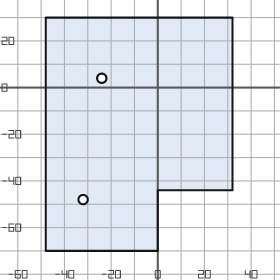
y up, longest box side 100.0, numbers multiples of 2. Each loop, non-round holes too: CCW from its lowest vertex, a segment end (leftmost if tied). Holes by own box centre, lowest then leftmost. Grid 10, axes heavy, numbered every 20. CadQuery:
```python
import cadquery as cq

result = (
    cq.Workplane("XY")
    .moveTo(-48.0, -70.0)
    .lineTo(0.0, -70.0)
    .lineTo(0.0, -44.0)
    .lineTo(32.0, -44.0)
    .lineTo(32.0, 30.0)
    .lineTo(-48.0, 30.0)
    .close()
    .moveTo(-32.0, -48.0)
    .circle(2.0)
    .moveTo(-24.0, 4.0)
    .circle(2.0)
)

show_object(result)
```